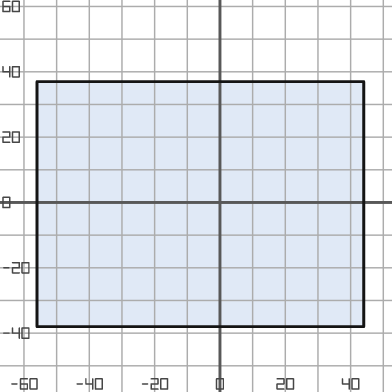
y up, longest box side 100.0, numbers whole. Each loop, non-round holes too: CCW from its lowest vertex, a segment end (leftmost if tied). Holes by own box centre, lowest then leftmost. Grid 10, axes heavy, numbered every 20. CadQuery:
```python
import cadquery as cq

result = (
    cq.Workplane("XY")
    .moveTo(-56.0, -38.0)
    .lineTo(44.0, -38.0)
    .lineTo(44.0, 37.0)
    .lineTo(-56.0, 37.0)
    .close()
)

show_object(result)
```